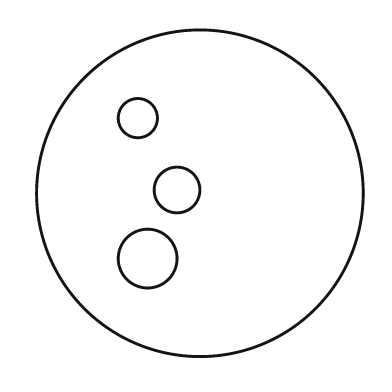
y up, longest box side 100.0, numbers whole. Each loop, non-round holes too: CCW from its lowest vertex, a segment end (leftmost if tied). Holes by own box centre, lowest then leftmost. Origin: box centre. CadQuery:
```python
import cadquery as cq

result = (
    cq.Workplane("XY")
    .moveTo(0.0, 0.0)
    .circle(50.0)
    .moveTo(-16.0, -20.0)
    .circle(9.0)
    .moveTo(-7.0, 1.0)
    .circle(7.0)
    .moveTo(-19.0, 23.0)
    .circle(6.0)
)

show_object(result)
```